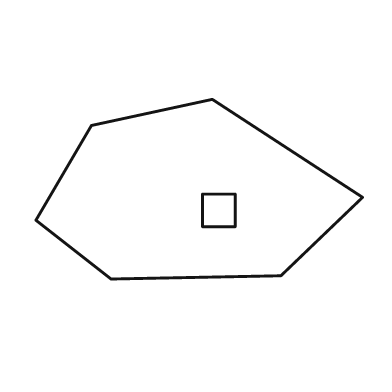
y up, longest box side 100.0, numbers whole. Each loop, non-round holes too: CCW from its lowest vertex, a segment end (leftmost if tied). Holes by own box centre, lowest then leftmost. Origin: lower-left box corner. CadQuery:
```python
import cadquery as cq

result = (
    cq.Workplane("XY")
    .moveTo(23.0, 0.0)
    .lineTo(75.0, 1.0)
    .lineTo(100.0, 25.0)
    .lineTo(54.0, 55.0)
    .lineTo(17.0, 47.0)
    .lineTo(0.0, 18.0)
    .close()
    .moveTo(51.0, 16.0)
    .lineTo(61.0, 16.0)
    .lineTo(61.0, 26.0)
    .lineTo(51.0, 26.0)
    .close()
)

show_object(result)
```